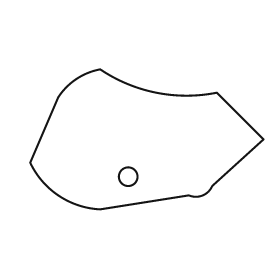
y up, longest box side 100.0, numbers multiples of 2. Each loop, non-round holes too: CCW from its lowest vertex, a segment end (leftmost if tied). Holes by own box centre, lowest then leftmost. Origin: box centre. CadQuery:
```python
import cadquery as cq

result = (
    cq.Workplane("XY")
    .moveTo(-20.0, -30.0)
    .lineTo(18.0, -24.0)
    .threePointArc((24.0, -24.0), (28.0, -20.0))
    .lineTo(50.0, 0.0)
    .lineTo(30.0, 20.0)
    .threePointArc((4.0, 20.0), (-20.0, 30.0))
    .threePointArc((-30.0, 26.0), (-38.0, 18.0))
    .lineTo(-50.0, -10.0)
    .threePointArc((-38.0, -24.0), (-20.0, -30.0))
    .close()
    .moveTo(-8.0, -16.0)
    .circle(4.0)
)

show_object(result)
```